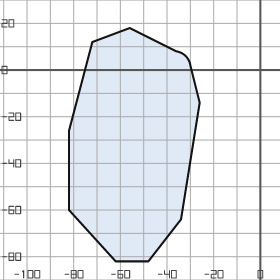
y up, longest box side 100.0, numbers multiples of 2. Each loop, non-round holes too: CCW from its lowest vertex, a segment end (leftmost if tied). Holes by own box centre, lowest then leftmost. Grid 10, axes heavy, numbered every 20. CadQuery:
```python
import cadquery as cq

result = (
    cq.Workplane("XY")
    .moveTo(-62.0, -82.0)
    .lineTo(-48.0, -82.0)
    .lineTo(-34.0, -64.0)
    .lineTo(-26.0, -14.0)
    .lineTo(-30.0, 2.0)
    .threePointArc((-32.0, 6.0), (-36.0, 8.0))
    .lineTo(-56.0, 18.0)
    .lineTo(-72.0, 12.0)
    .lineTo(-82.0, -26.0)
    .lineTo(-82.0, -60.0)
    .close()
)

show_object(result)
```